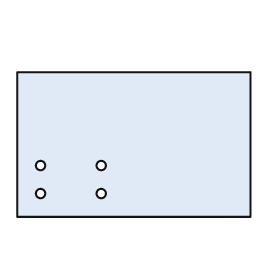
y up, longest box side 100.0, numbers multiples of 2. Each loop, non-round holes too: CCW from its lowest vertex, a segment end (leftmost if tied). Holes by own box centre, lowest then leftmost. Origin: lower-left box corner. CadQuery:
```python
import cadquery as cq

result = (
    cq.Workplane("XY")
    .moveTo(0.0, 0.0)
    .lineTo(100.0, 0.0)
    .lineTo(100.0, 62.0)
    .lineTo(0.0, 62.0)
    .close()
    .moveTo(10.0, 10.0)
    .circle(2.0)
    .moveTo(36.0, 10.0)
    .circle(2.0)
    .moveTo(10.0, 22.0)
    .circle(2.0)
    .moveTo(36.0, 22.0)
    .circle(2.0)
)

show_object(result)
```